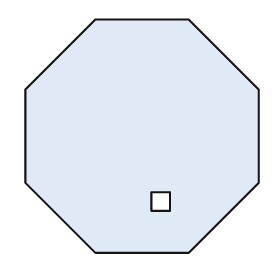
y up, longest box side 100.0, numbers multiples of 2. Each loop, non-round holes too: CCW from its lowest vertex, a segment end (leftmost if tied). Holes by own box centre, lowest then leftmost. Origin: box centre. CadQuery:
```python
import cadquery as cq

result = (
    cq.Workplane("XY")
    .moveTo(-20.0, -50.0)
    .lineTo(20.0, -50.0)
    .lineTo(50.0, -20.0)
    .lineTo(50.0, 20.0)
    .lineTo(20.0, 50.0)
    .lineTo(-20.0, 50.0)
    .lineTo(-50.0, 20.0)
    .lineTo(-50.0, -20.0)
    .close()
    .moveTo(4.0, -32.0)
    .lineTo(12.0, -32.0)
    .lineTo(12.0, -24.0)
    .lineTo(4.0, -24.0)
    .close()
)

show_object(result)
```